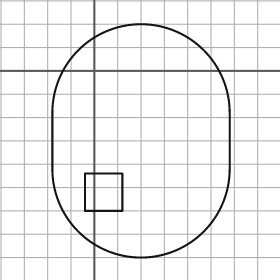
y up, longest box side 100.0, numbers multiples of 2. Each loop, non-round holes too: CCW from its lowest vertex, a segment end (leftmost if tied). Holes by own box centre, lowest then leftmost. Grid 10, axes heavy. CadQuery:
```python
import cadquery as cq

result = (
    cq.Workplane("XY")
    .moveTo(-18.0, -42.0)
    .threePointArc((20.0, -80.0), (58.0, -42.0))
    .lineTo(58.0, -18.0)
    .threePointArc((20.0, 20.0), (-18.0, -18.0))
    .close()
    .moveTo(-4.0, -60.0)
    .lineTo(12.0, -60.0)
    .lineTo(12.0, -44.0)
    .lineTo(-4.0, -44.0)
    .close()
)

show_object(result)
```